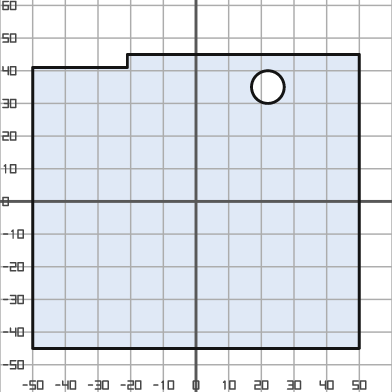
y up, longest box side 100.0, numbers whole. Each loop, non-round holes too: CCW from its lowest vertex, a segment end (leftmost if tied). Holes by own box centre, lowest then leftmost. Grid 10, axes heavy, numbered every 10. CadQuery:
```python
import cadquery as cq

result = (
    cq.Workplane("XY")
    .moveTo(-50.0, -45.0)
    .lineTo(50.0, -45.0)
    .lineTo(50.0, 45.0)
    .lineTo(-21.0, 45.0)
    .lineTo(-21.0, 41.0)
    .lineTo(-50.0, 41.0)
    .close()
    .moveTo(22.0, 35.0)
    .circle(5.0)
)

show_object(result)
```